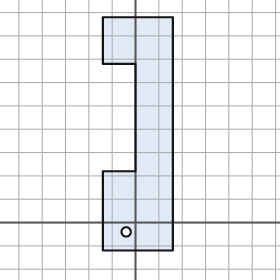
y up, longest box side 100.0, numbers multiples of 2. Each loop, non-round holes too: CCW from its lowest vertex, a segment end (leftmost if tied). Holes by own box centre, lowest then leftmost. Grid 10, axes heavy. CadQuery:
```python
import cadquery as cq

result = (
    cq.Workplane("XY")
    .moveTo(-14.0, -12.0)
    .lineTo(16.0, -12.0)
    .lineTo(16.0, 88.0)
    .lineTo(-14.0, 88.0)
    .lineTo(-14.0, 68.0)
    .lineTo(0.0, 68.0)
    .lineTo(0.0, 22.0)
    .lineTo(-14.0, 22.0)
    .close()
    .moveTo(-4.0, -4.0)
    .circle(2.0)
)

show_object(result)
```